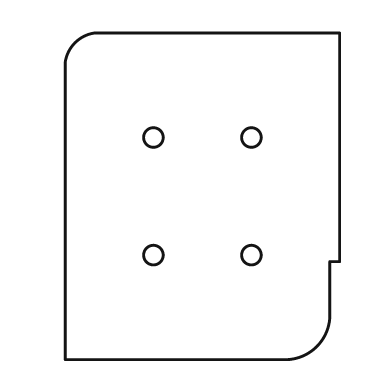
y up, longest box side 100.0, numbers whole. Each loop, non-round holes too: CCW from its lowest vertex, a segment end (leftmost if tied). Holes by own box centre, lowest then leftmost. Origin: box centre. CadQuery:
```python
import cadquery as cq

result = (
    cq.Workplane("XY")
    .moveTo(-42.0, -50.0)
    .lineTo(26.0, -50.0)
    .threePointArc((35.0, -46.0), (39.0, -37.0))
    .lineTo(39.0, -20.0)
    .lineTo(42.0, -20.0)
    .lineTo(42.0, 50.0)
    .lineTo(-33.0, 50.0)
    .threePointArc((-39.0, 47.0), (-42.0, 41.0))
    .close()
    .moveTo(-15.0, -18.0)
    .circle(3.0)
    .moveTo(15.0, -18.0)
    .circle(3.0)
    .moveTo(-15.0, 18.0)
    .circle(3.0)
    .moveTo(15.0, 18.0)
    .circle(3.0)
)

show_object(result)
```